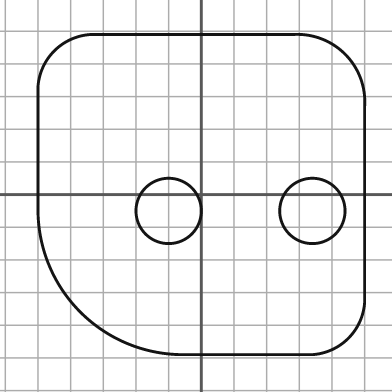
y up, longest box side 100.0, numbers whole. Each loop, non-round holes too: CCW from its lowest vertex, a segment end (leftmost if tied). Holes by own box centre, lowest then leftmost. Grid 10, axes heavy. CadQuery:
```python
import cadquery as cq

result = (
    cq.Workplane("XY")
    .moveTo(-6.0, -49.0)
    .lineTo(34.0, -49.0)
    .threePointArc((45.0, -44.0), (50.0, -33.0))
    .lineTo(50.0, 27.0)
    .threePointArc((44.0, 43.0), (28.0, 49.0))
    .lineTo(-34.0, 49.0)
    .threePointArc((-45.0, 44.0), (-50.0, 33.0))
    .lineTo(-50.0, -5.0)
    .threePointArc((-37.0, -36.0), (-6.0, -49.0))
    .close()
    .moveTo(-10.0, -5.0)
    .circle(10.0)
    .moveTo(34.0, -5.0)
    .circle(10.0)
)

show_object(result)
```